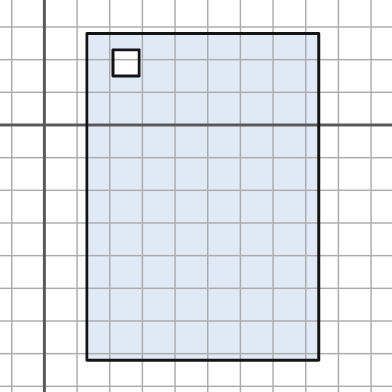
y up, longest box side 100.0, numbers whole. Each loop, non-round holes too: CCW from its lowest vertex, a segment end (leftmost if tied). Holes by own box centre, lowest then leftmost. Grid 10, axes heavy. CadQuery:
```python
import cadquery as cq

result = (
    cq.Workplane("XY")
    .moveTo(13.0, -72.0)
    .lineTo(84.0, -72.0)
    .lineTo(84.0, 28.0)
    .lineTo(13.0, 28.0)
    .close()
    .moveTo(21.0, 15.0)
    .lineTo(29.0, 15.0)
    .lineTo(29.0, 23.0)
    .lineTo(21.0, 23.0)
    .close()
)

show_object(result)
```